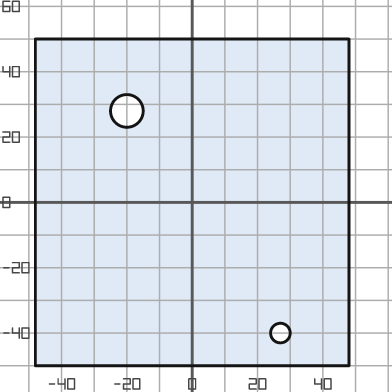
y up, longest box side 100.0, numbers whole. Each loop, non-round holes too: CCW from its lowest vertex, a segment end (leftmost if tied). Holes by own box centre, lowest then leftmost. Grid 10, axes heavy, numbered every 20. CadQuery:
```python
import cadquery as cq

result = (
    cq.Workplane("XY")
    .moveTo(-48.0, -50.0)
    .lineTo(48.0, -50.0)
    .lineTo(48.0, 50.0)
    .lineTo(-48.0, 50.0)
    .close()
    .moveTo(27.0, -40.0)
    .circle(3.0)
    .moveTo(-20.0, 28.0)
    .circle(5.0)
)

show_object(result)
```